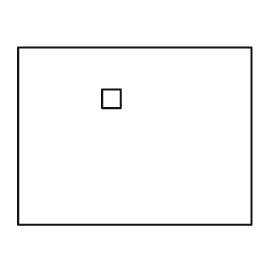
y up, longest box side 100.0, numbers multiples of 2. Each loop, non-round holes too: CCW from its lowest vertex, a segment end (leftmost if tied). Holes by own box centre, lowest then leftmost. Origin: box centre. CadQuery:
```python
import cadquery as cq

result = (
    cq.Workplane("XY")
    .moveTo(-50.0, -38.0)
    .lineTo(50.0, -38.0)
    .lineTo(50.0, 38.0)
    .lineTo(-50.0, 38.0)
    .close()
    .moveTo(-14.0, 12.0)
    .lineTo(-6.0, 12.0)
    .lineTo(-6.0, 20.0)
    .lineTo(-14.0, 20.0)
    .close()
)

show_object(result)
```